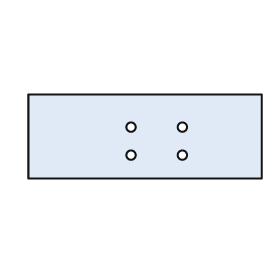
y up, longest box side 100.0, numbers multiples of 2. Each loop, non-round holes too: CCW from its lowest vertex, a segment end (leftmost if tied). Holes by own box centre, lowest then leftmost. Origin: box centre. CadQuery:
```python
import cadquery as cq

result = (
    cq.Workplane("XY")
    .moveTo(-50.0, -18.0)
    .lineTo(50.0, -18.0)
    .lineTo(50.0, 18.0)
    .lineTo(-50.0, 18.0)
    .close()
    .moveTo(-6.0, -8.0)
    .circle(2.0)
    .moveTo(16.0, -8.0)
    .circle(2.0)
    .moveTo(-6.0, 4.0)
    .circle(2.0)
    .moveTo(16.0, 4.0)
    .circle(2.0)
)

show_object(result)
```